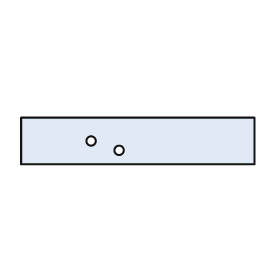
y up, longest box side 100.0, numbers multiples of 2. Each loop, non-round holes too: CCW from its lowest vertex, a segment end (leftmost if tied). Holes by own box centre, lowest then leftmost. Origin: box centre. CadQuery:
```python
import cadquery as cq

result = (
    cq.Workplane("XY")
    .moveTo(-50.0, -10.0)
    .lineTo(50.0, -10.0)
    .lineTo(50.0, 10.0)
    .lineTo(-50.0, 10.0)
    .close()
    .moveTo(-8.0, -4.0)
    .circle(2.0)
    .moveTo(-20.0, 0.0)
    .circle(2.0)
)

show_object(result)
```